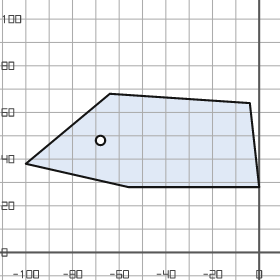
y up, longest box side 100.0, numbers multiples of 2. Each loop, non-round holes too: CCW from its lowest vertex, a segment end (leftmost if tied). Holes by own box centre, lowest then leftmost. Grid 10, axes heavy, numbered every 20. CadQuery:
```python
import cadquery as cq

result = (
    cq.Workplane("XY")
    .moveTo(-56.0, 28.0)
    .lineTo(0.0, 28.0)
    .lineTo(-4.0, 64.0)
    .lineTo(-64.0, 68.0)
    .lineTo(-100.0, 38.0)
    .close()
    .moveTo(-68.0, 48.0)
    .circle(2.0)
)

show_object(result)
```